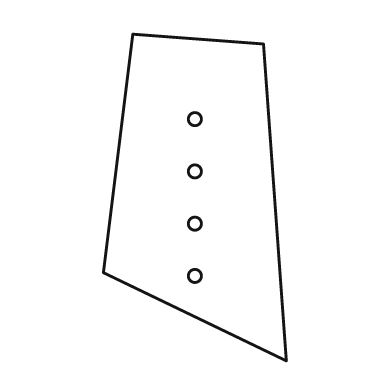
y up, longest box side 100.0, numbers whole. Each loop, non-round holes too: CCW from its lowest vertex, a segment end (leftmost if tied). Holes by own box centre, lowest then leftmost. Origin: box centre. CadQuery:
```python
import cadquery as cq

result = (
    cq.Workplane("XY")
    .moveTo(28.0, -50.0)
    .lineTo(21.0, 47.0)
    .lineTo(-19.0, 50.0)
    .lineTo(-28.0, -23.0)
    .close()
    .moveTo(0.0, -24.0)
    .circle(2.0)
    .moveTo(0.0, -8.0)
    .circle(2.0)
    .moveTo(0.0, 8.0)
    .circle(2.0)
    .moveTo(0.0, 24.0)
    .circle(2.0)
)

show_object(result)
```